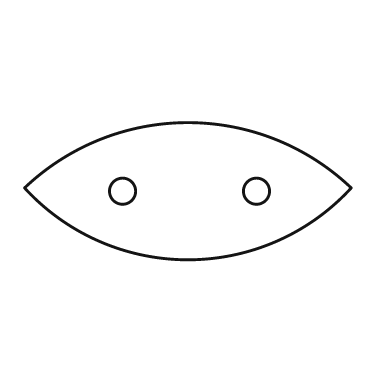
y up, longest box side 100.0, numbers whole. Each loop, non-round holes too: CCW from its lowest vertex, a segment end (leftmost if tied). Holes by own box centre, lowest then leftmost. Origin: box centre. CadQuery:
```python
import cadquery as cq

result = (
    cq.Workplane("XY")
    .moveTo(-50.0, 1.0)
    .threePointArc((0.0, -21.0), (50.0, 1.0))
    .threePointArc((0.0, 21.0), (-50.0, 1.0))
    .close()
    .moveTo(-20.0, 0.0)
    .circle(4.0)
    .moveTo(21.0, 0.0)
    .circle(4.0)
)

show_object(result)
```